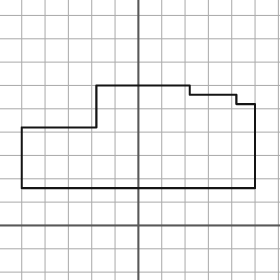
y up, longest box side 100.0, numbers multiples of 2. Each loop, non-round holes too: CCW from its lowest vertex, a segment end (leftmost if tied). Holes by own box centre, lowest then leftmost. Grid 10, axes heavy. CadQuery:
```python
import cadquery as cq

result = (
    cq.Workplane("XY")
    .moveTo(-50.0, 16.0)
    .lineTo(50.0, 16.0)
    .lineTo(50.0, 52.0)
    .lineTo(42.0, 52.0)
    .lineTo(42.0, 56.0)
    .lineTo(22.0, 56.0)
    .lineTo(22.0, 60.0)
    .lineTo(-18.0, 60.0)
    .lineTo(-18.0, 42.0)
    .lineTo(-50.0, 42.0)
    .close()
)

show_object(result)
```